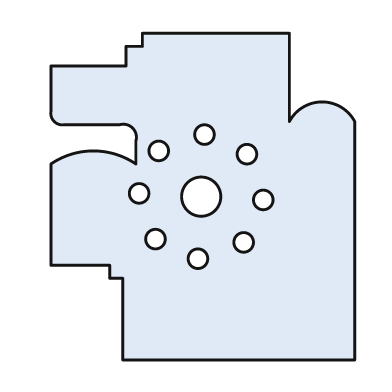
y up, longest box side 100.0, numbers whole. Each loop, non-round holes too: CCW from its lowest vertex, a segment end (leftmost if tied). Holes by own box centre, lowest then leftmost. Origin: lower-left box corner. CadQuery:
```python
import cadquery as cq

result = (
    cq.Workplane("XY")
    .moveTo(22.0, 0.0)
    .lineTo(93.0, 0.0)
    .lineTo(93.0, 73.0)
    .threePointArc((83.0, 79.0), (73.0, 73.0))
    .lineTo(73.0, 100.0)
    .lineTo(28.0, 100.0)
    .lineTo(28.0, 96.0)
    .lineTo(23.0, 96.0)
    .lineTo(23.0, 90.0)
    .lineTo(0.0, 90.0)
    .lineTo(0.0, 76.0)
    .threePointArc((1.0, 73.0), (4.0, 72.0))
    .lineTo(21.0, 72.0)
    .threePointArc((25.0, 71.0), (26.0, 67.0))
    .lineTo(26.0, 60.0)
    .threePointArc((13.0, 64.0), (0.0, 60.0))
    .lineTo(0.0, 29.0)
    .lineTo(18.0, 29.0)
    .lineTo(18.0, 25.0)
    .lineTo(22.0, 25.0)
    .close()
    .moveTo(45.0, 31.0)
    .circle(3.0)
    .moveTo(59.0, 36.0)
    .circle(3.0)
    .moveTo(32.0, 37.0)
    .circle(3.0)
    .moveTo(65.0, 49.0)
    .circle(3.0)
    .moveTo(46.0, 50.0)
    .circle(6.0)
    .moveTo(27.0, 51.0)
    .circle(3.0)
    .moveTo(60.0, 63.0)
    .circle(3.0)
    .moveTo(33.0, 64.0)
    .circle(3.0)
    .moveTo(47.0, 69.0)
    .circle(3.0)
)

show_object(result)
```